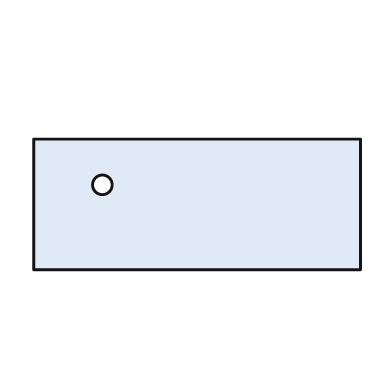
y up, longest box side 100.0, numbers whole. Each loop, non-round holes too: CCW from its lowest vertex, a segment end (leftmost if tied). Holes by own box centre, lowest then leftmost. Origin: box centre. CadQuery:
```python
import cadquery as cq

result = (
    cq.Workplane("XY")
    .moveTo(-50.0, -20.0)
    .lineTo(50.0, -20.0)
    .lineTo(50.0, 20.0)
    .lineTo(-50.0, 20.0)
    .close()
    .moveTo(-29.0, 6.0)
    .circle(3.0)
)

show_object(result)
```